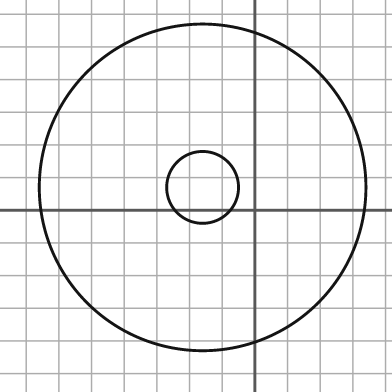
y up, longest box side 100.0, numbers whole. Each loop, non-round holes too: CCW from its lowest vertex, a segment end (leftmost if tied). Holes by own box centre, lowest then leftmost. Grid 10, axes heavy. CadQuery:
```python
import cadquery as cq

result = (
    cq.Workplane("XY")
    .moveTo(-16.0, 7.0)
    .circle(50.0)
    .moveTo(-16.0, 7.0)
    .circle(11.0)
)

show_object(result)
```